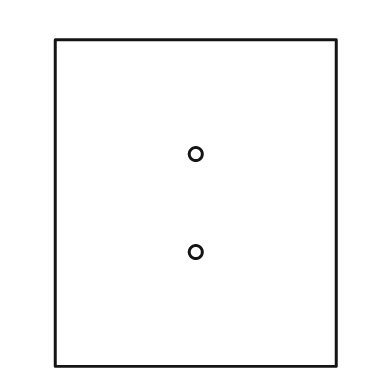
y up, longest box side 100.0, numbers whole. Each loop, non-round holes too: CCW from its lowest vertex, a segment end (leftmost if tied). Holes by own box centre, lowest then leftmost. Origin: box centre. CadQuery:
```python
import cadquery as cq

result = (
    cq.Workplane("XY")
    .moveTo(-43.0, -50.0)
    .lineTo(43.0, -50.0)
    .lineTo(43.0, 50.0)
    .lineTo(-43.0, 50.0)
    .close()
    .moveTo(0.0, -15.0)
    .circle(2.0)
    .moveTo(0.0, 15.0)
    .circle(2.0)
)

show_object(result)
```